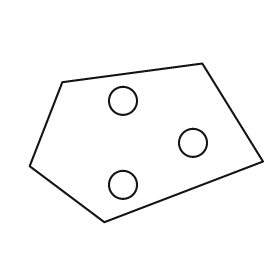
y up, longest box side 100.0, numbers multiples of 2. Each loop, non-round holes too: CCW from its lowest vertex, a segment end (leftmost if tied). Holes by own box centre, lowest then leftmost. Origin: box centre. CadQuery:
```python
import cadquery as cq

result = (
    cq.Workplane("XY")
    .moveTo(-18.0, -34.0)
    .lineTo(50.0, -8.0)
    .lineTo(24.0, 34.0)
    .lineTo(-36.0, 26.0)
    .lineTo(-50.0, -10.0)
    .close()
    .moveTo(-10.0, -18.0)
    .circle(6.0)
    .moveTo(20.0, 0.0)
    .circle(6.0)
    .moveTo(-10.0, 18.0)
    .circle(6.0)
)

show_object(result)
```